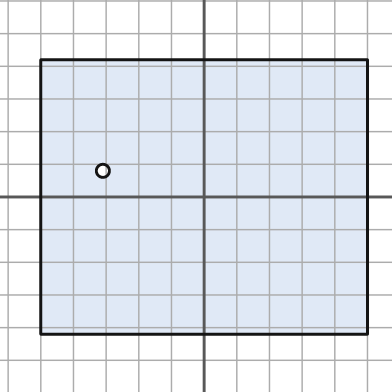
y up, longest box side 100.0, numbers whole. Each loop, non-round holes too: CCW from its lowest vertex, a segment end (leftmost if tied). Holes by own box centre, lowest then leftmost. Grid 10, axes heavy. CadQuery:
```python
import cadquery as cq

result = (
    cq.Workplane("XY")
    .moveTo(-50.0, -42.0)
    .lineTo(50.0, -42.0)
    .lineTo(50.0, 42.0)
    .lineTo(-50.0, 42.0)
    .close()
    .moveTo(-31.0, 8.0)
    .circle(2.0)
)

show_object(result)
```